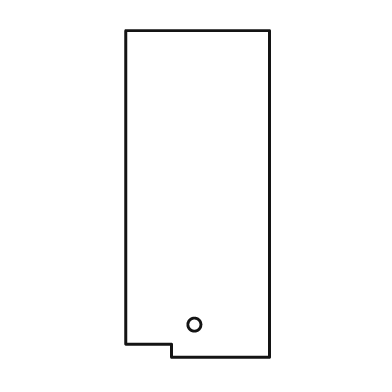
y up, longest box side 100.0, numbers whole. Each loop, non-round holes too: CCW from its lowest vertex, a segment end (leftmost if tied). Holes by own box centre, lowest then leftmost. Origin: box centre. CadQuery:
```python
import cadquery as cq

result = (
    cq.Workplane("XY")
    .moveTo(-8.0, -50.0)
    .lineTo(22.0, -50.0)
    .lineTo(22.0, 50.0)
    .lineTo(-22.0, 50.0)
    .lineTo(-22.0, -46.0)
    .lineTo(-8.0, -46.0)
    .close()
    .moveTo(-1.0, -40.0)
    .circle(2.0)
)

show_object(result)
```